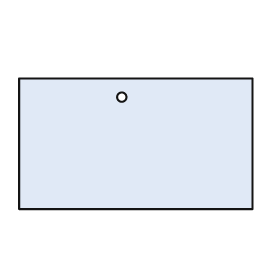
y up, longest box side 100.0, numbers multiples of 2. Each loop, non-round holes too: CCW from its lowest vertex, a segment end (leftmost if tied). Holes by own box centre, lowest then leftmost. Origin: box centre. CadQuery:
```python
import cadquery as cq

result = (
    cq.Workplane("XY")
    .moveTo(-50.0, -28.0)
    .lineTo(50.0, -28.0)
    .lineTo(50.0, 28.0)
    .lineTo(-50.0, 28.0)
    .close()
    .moveTo(-6.0, 20.0)
    .circle(2.0)
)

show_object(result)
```